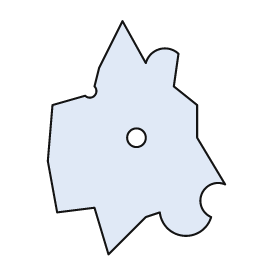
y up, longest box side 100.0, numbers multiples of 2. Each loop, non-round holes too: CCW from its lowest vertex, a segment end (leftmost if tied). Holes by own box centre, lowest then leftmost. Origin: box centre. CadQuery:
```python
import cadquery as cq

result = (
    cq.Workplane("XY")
    .moveTo(-12.0, -50.0)
    .lineTo(4.0, -34.0)
    .lineTo(10.0, -32.0)
    .threePointArc((20.0, -42.0), (32.0, -34.0))
    .threePointArc((28.0, -24.0), (38.0, -20.0))
    .lineTo(26.0, 0.0)
    .lineTo(26.0, 14.0)
    .lineTo(16.0, 22.0)
    .lineTo(18.0, 36.0)
    .threePointArc((10.0, 38.0), (4.0, 32.0))
    .lineTo(-6.0, 50.0)
    .lineTo(-16.0, 30.0)
    .lineTo(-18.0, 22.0)
    .threePointArc((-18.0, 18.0), (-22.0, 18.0))
    .lineTo(-36.0, 14.0)
    .lineTo(-38.0, -10.0)
    .lineTo(-34.0, -32.0)
    .lineTo(-18.0, -30.0)
    .close()
    .moveTo(0.0, 0.0)
    .circle(4.0)
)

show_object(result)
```